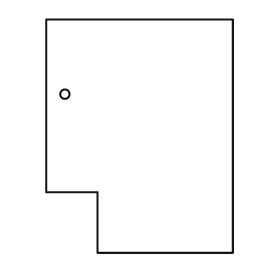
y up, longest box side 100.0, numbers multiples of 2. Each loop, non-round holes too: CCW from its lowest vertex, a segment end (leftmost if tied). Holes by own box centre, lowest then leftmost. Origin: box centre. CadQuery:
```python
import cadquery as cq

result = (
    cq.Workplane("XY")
    .moveTo(-18.0, -50.0)
    .lineTo(40.0, -50.0)
    .lineTo(40.0, 50.0)
    .lineTo(-40.0, 50.0)
    .lineTo(-40.0, -24.0)
    .lineTo(-18.0, -24.0)
    .close()
    .moveTo(-32.0, 18.0)
    .circle(2.0)
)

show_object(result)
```